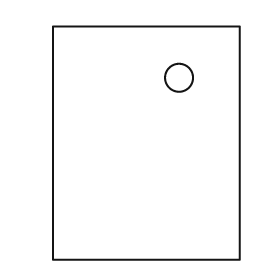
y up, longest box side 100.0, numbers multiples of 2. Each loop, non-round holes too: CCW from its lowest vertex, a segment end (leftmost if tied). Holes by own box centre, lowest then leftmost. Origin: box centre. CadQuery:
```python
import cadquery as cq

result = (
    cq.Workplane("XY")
    .moveTo(-40.0, -50.0)
    .lineTo(40.0, -50.0)
    .lineTo(40.0, 50.0)
    .lineTo(-40.0, 50.0)
    .close()
    .moveTo(14.0, 28.0)
    .circle(6.0)
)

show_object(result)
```